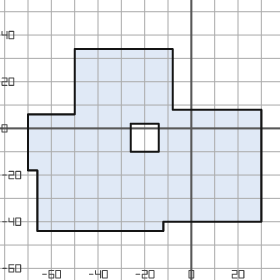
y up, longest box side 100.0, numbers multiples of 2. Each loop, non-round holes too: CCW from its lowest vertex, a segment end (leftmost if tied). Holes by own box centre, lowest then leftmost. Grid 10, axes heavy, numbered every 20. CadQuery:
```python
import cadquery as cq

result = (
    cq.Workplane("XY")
    .moveTo(-66.0, -44.0)
    .lineTo(-12.0, -44.0)
    .lineTo(-12.0, -40.0)
    .lineTo(30.0, -40.0)
    .lineTo(30.0, 8.0)
    .lineTo(-8.0, 8.0)
    .lineTo(-8.0, 34.0)
    .lineTo(-50.0, 34.0)
    .lineTo(-50.0, 6.0)
    .lineTo(-70.0, 6.0)
    .lineTo(-70.0, -18.0)
    .lineTo(-66.0, -18.0)
    .close()
    .moveTo(-26.0, -10.0)
    .lineTo(-14.0, -10.0)
    .lineTo(-14.0, 2.0)
    .lineTo(-26.0, 2.0)
    .close()
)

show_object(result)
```